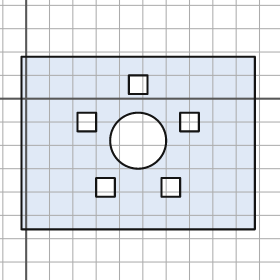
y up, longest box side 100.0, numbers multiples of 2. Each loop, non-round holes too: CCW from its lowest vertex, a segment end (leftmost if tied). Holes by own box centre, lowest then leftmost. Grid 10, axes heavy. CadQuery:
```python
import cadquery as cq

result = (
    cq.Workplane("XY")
    .moveTo(-2.0, -56.0)
    .lineTo(98.0, -56.0)
    .lineTo(98.0, 18.0)
    .lineTo(-2.0, 18.0)
    .close()
    .moveTo(30.0, -42.0)
    .lineTo(38.0, -42.0)
    .lineTo(38.0, -34.0)
    .lineTo(30.0, -34.0)
    .close()
    .moveTo(58.0, -42.0)
    .lineTo(66.0, -42.0)
    .lineTo(66.0, -34.0)
    .lineTo(58.0, -34.0)
    .close()
    .moveTo(48.0, -18.0)
    .circle(12.0)
    .moveTo(22.0, -14.0)
    .lineTo(30.0, -14.0)
    .lineTo(30.0, -6.0)
    .lineTo(22.0, -6.0)
    .close()
    .moveTo(66.0, -14.0)
    .lineTo(74.0, -14.0)
    .lineTo(74.0, -6.0)
    .lineTo(66.0, -6.0)
    .close()
    .moveTo(44.0, 2.0)
    .lineTo(52.0, 2.0)
    .lineTo(52.0, 10.0)
    .lineTo(44.0, 10.0)
    .close()
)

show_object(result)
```